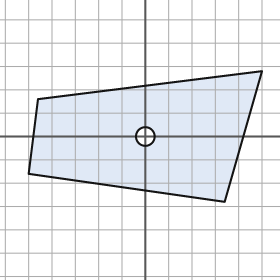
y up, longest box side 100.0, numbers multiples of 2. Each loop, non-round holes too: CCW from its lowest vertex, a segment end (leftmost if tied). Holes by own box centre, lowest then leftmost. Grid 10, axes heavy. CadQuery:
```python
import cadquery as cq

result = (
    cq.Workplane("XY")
    .moveTo(34.0, -28.0)
    .lineTo(50.0, 28.0)
    .lineTo(-46.0, 16.0)
    .lineTo(-50.0, -16.0)
    .close()
    .moveTo(0.0, 0.0)
    .circle(4.0)
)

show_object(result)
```